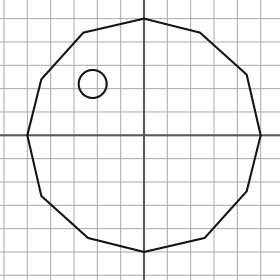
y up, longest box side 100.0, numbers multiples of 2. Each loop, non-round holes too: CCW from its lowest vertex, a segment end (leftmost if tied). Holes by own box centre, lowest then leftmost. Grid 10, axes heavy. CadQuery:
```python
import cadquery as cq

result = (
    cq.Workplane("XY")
    .moveTo(0.0, -50.0)
    .lineTo(26.0, -44.0)
    .lineTo(44.0, -24.0)
    .lineTo(50.0, 0.0)
    .lineTo(44.0, 26.0)
    .lineTo(24.0, 44.0)
    .lineTo(0.0, 50.0)
    .lineTo(-26.0, 44.0)
    .lineTo(-44.0, 24.0)
    .lineTo(-50.0, 0.0)
    .lineTo(-44.0, -26.0)
    .lineTo(-24.0, -44.0)
    .close()
    .moveTo(-22.0, 22.0)
    .circle(6.0)
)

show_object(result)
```